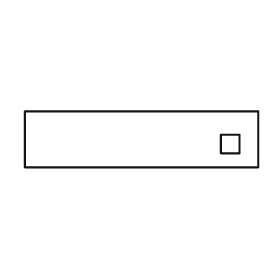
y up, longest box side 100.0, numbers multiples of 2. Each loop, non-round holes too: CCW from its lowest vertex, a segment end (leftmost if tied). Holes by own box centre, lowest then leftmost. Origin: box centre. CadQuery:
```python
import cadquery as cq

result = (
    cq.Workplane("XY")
    .moveTo(-50.0, -12.0)
    .lineTo(50.0, -12.0)
    .lineTo(50.0, 12.0)
    .lineTo(-50.0, 12.0)
    .close()
    .moveTo(34.0, -6.0)
    .lineTo(42.0, -6.0)
    .lineTo(42.0, 2.0)
    .lineTo(34.0, 2.0)
    .close()
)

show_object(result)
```